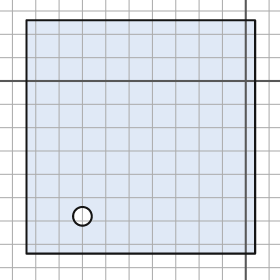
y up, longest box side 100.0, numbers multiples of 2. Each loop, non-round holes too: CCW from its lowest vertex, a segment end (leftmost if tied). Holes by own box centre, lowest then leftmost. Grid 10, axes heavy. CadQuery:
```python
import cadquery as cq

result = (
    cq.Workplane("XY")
    .moveTo(-94.0, -74.0)
    .lineTo(4.0, -74.0)
    .lineTo(4.0, 26.0)
    .lineTo(-94.0, 26.0)
    .close()
    .moveTo(-70.0, -58.0)
    .circle(4.0)
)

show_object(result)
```